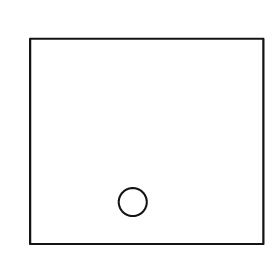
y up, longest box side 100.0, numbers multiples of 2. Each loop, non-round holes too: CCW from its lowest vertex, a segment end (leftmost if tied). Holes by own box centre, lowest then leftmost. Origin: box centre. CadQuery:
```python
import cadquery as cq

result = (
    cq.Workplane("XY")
    .moveTo(-50.0, -44.0)
    .lineTo(50.0, -44.0)
    .lineTo(50.0, 44.0)
    .lineTo(-50.0, 44.0)
    .close()
    .moveTo(-6.0, -26.0)
    .circle(6.0)
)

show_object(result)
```